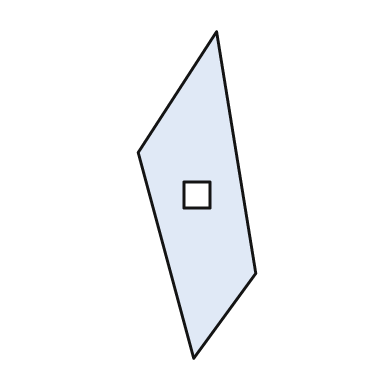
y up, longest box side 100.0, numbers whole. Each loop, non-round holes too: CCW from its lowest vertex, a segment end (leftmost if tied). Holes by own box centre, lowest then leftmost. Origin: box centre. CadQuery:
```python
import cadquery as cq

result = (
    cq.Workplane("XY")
    .moveTo(-1.0, -50.0)
    .lineTo(18.0, -24.0)
    .lineTo(6.0, 50.0)
    .lineTo(-18.0, 13.0)
    .close()
    .moveTo(-4.0, -4.0)
    .lineTo(4.0, -4.0)
    .lineTo(4.0, 4.0)
    .lineTo(-4.0, 4.0)
    .close()
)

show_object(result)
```